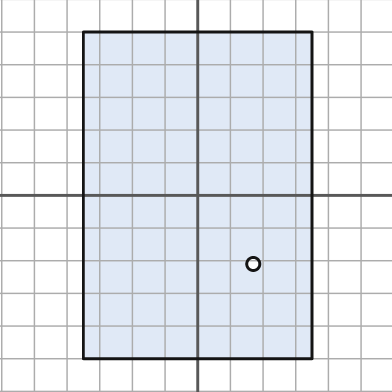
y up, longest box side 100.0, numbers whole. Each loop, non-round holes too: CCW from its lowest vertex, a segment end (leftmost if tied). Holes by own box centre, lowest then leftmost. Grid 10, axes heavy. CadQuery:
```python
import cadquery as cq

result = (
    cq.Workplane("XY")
    .moveTo(-35.0, -50.0)
    .lineTo(35.0, -50.0)
    .lineTo(35.0, 50.0)
    .lineTo(-35.0, 50.0)
    .close()
    .moveTo(17.0, -21.0)
    .circle(2.0)
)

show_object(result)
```